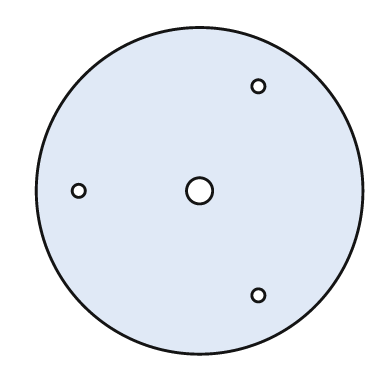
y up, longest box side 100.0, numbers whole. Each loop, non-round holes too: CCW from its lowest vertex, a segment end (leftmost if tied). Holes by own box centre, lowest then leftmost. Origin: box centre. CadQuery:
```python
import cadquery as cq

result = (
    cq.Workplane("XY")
    .moveTo(0.0, 0.0)
    .circle(50.0)
    .moveTo(18.0, -32.0)
    .circle(2.0)
    .moveTo(-37.0, 0.0)
    .circle(2.0)
    .moveTo(0.0, 0.0)
    .circle(4.0)
    .moveTo(18.0, 32.0)
    .circle(2.0)
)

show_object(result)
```